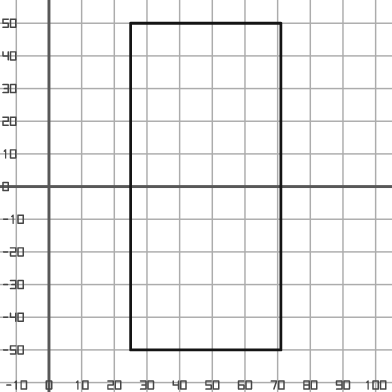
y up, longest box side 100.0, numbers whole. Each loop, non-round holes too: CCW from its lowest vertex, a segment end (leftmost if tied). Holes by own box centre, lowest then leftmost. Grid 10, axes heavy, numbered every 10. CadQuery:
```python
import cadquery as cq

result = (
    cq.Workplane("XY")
    .moveTo(25.0, -50.0)
    .lineTo(71.0, -50.0)
    .lineTo(71.0, 50.0)
    .lineTo(25.0, 50.0)
    .close()
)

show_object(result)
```